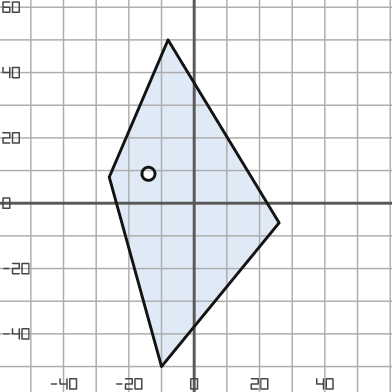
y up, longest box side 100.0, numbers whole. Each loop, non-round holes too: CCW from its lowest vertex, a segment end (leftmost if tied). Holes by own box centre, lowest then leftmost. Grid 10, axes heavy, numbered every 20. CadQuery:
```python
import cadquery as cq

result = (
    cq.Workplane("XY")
    .moveTo(-10.0, -50.0)
    .lineTo(26.0, -6.0)
    .lineTo(-8.0, 50.0)
    .lineTo(-26.0, 8.0)
    .close()
    .moveTo(-14.0, 9.0)
    .circle(2.0)
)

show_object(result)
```